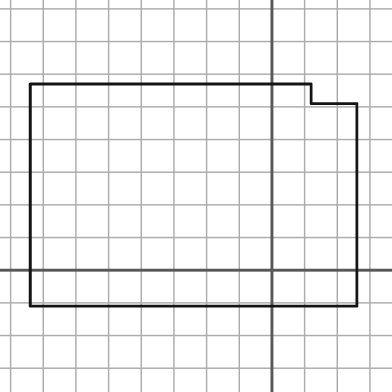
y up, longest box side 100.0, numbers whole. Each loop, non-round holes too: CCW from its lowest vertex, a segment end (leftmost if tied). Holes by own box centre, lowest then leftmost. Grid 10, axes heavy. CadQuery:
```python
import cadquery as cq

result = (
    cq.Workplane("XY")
    .moveTo(-74.0, -11.0)
    .lineTo(26.0, -11.0)
    .lineTo(26.0, 51.0)
    .lineTo(12.0, 51.0)
    .lineTo(12.0, 57.0)
    .lineTo(-74.0, 57.0)
    .close()
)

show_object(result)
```